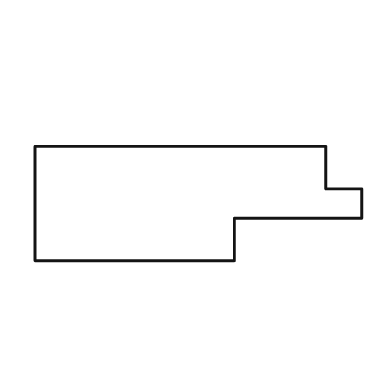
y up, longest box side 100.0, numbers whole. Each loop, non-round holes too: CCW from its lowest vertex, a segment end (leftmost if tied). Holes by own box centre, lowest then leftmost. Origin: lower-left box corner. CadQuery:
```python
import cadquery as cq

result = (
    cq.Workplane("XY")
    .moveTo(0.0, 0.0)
    .lineTo(61.0, 0.0)
    .lineTo(61.0, 13.0)
    .lineTo(100.0, 13.0)
    .lineTo(100.0, 22.0)
    .lineTo(89.0, 22.0)
    .lineTo(89.0, 35.0)
    .lineTo(0.0, 35.0)
    .close()
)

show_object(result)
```